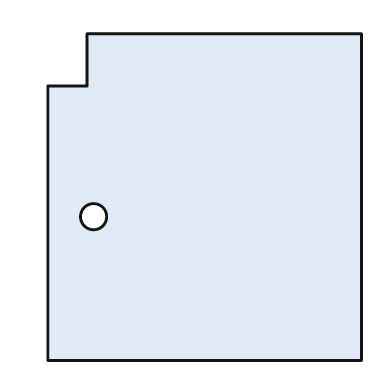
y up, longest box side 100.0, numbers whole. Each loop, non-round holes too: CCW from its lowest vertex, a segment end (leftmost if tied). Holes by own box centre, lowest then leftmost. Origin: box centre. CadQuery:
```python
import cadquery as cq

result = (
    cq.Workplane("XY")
    .moveTo(-48.0, -50.0)
    .lineTo(48.0, -50.0)
    .lineTo(48.0, 50.0)
    .lineTo(-36.0, 50.0)
    .lineTo(-36.0, 34.0)
    .lineTo(-48.0, 34.0)
    .close()
    .moveTo(-34.0, -6.0)
    .circle(4.0)
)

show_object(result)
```